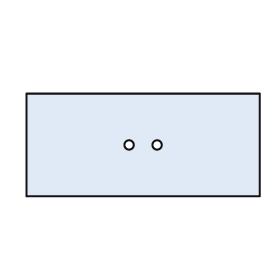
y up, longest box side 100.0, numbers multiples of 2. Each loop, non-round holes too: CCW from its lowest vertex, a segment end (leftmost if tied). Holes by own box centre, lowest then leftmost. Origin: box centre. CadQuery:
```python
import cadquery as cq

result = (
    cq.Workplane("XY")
    .moveTo(-50.0, -22.0)
    .lineTo(50.0, -22.0)
    .lineTo(50.0, 22.0)
    .lineTo(-50.0, 22.0)
    .close()
    .moveTo(-6.0, 0.0)
    .circle(2.0)
    .moveTo(6.0, 0.0)
    .circle(2.0)
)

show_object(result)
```